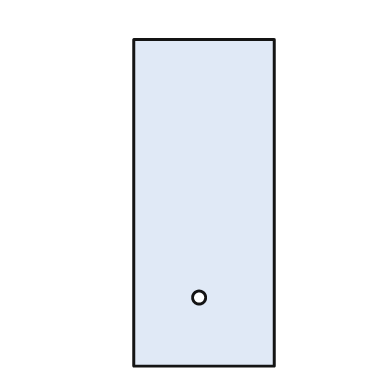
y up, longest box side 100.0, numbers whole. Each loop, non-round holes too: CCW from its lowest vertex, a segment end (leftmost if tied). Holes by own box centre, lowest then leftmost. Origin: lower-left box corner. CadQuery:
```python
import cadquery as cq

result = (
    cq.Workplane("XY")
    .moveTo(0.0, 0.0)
    .lineTo(43.0, 0.0)
    .lineTo(43.0, 100.0)
    .lineTo(0.0, 100.0)
    .close()
    .moveTo(20.0, 21.0)
    .circle(2.0)
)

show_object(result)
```